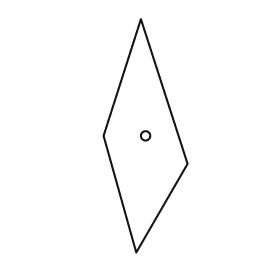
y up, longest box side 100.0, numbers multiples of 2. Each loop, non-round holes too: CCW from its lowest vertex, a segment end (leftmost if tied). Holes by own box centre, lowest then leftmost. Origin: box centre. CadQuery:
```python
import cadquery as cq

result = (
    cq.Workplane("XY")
    .moveTo(-4.0, -50.0)
    .lineTo(18.0, -12.0)
    .lineTo(-2.0, 50.0)
    .lineTo(-18.0, 0.0)
    .close()
    .moveTo(0.0, 0.0)
    .circle(2.0)
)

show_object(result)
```